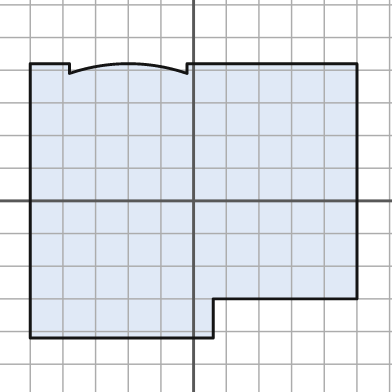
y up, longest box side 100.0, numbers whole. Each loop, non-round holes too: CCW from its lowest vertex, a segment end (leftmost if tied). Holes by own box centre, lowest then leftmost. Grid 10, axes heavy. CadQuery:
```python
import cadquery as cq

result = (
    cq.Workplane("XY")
    .moveTo(-50.0, -42.0)
    .lineTo(6.0, -42.0)
    .lineTo(6.0, -30.0)
    .lineTo(50.0, -30.0)
    .lineTo(50.0, 42.0)
    .lineTo(-2.0, 42.0)
    .lineTo(-2.0, 39.0)
    .threePointArc((-20.0, 42.0), (-38.0, 39.0))
    .lineTo(-38.0, 42.0)
    .lineTo(-50.0, 42.0)
    .close()
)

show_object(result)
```